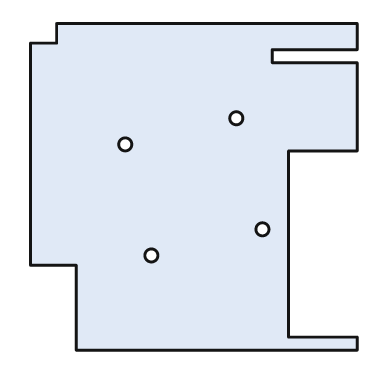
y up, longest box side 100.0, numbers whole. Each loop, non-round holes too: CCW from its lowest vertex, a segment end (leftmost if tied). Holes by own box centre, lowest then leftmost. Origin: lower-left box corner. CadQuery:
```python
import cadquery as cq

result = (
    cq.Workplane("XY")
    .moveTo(14.0, 0.0)
    .lineTo(100.0, 0.0)
    .lineTo(100.0, 4.0)
    .lineTo(79.0, 4.0)
    .lineTo(79.0, 61.0)
    .lineTo(100.0, 61.0)
    .lineTo(100.0, 88.0)
    .lineTo(74.0, 88.0)
    .lineTo(74.0, 92.0)
    .lineTo(100.0, 92.0)
    .lineTo(100.0, 100.0)
    .lineTo(8.0, 100.0)
    .lineTo(8.0, 94.0)
    .lineTo(0.0, 94.0)
    .lineTo(0.0, 26.0)
    .lineTo(14.0, 26.0)
    .close()
    .moveTo(37.0, 29.0)
    .circle(2.0)
    .moveTo(71.0, 37.0)
    .circle(2.0)
    .moveTo(29.0, 63.0)
    .circle(2.0)
    .moveTo(63.0, 71.0)
    .circle(2.0)
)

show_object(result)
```